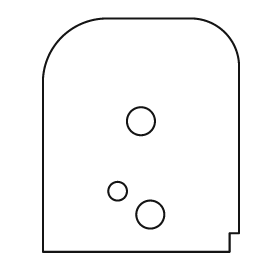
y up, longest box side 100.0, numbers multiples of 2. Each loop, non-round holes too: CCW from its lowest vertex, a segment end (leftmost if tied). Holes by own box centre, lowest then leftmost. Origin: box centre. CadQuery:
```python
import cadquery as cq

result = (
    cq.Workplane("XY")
    .moveTo(-42.0, -50.0)
    .lineTo(38.0, -50.0)
    .lineTo(38.0, -42.0)
    .lineTo(42.0, -42.0)
    .lineTo(42.0, 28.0)
    .threePointArc((36.0, 44.0), (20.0, 50.0))
    .lineTo(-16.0, 50.0)
    .threePointArc((-34.0, 42.0), (-42.0, 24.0))
    .close()
    .moveTo(4.0, -34.0)
    .circle(6.0)
    .moveTo(-10.0, -24.0)
    .circle(4.0)
    .moveTo(0.0, 6.0)
    .circle(6.0)
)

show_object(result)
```